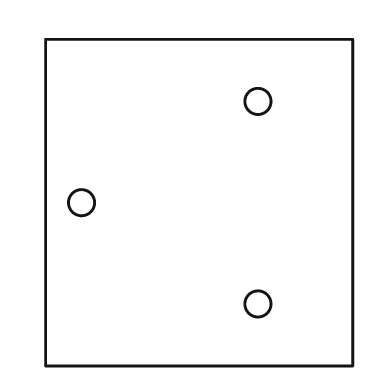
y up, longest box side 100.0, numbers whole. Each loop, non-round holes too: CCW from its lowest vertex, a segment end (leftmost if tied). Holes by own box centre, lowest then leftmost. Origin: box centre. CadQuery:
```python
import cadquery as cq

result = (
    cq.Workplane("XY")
    .moveTo(-47.0, -50.0)
    .lineTo(47.0, -50.0)
    .lineTo(47.0, 50.0)
    .lineTo(-47.0, 50.0)
    .close()
    .moveTo(18.0, -31.0)
    .circle(4.0)
    .moveTo(-36.0, 0.0)
    .circle(4.0)
    .moveTo(18.0, 31.0)
    .circle(4.0)
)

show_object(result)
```